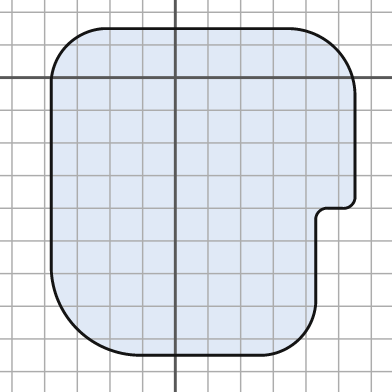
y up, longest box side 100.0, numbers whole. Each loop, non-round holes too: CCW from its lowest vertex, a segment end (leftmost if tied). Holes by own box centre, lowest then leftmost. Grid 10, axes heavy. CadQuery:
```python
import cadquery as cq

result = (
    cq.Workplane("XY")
    .moveTo(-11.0, -85.0)
    .lineTo(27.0, -85.0)
    .threePointArc((38.0, -80.0), (43.0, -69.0))
    .lineTo(43.0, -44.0)
    .threePointArc((44.0, -41.0), (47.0, -40.0))
    .lineTo(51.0, -40.0)
    .threePointArc((54.0, -39.0), (55.0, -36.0))
    .lineTo(55.0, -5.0)
    .threePointArc((49.0, 9.0), (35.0, 15.0))
    .lineTo(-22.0, 15.0)
    .threePointArc((-33.0, 10.0), (-38.0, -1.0))
    .lineTo(-38.0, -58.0)
    .threePointArc((-30.0, -77.0), (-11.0, -85.0))
    .close()
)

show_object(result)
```